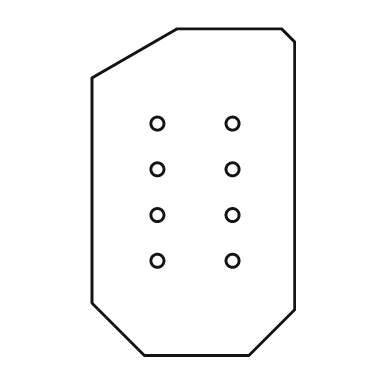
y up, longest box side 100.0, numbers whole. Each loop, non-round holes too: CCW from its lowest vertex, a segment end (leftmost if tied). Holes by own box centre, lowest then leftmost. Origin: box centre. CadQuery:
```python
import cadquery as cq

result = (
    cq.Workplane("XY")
    .moveTo(-15.0, -50.0)
    .lineTo(17.0, -50.0)
    .lineTo(31.0, -36.0)
    .lineTo(31.0, 46.0)
    .lineTo(27.0, 50.0)
    .lineTo(-5.0, 50.0)
    .lineTo(-31.0, 35.0)
    .lineTo(-31.0, -34.0)
    .close()
    .moveTo(-11.0, -21.0)
    .circle(2.0)
    .moveTo(12.0, -21.0)
    .circle(2.0)
    .moveTo(-11.0, -7.0)
    .circle(2.0)
    .moveTo(12.0, -7.0)
    .circle(2.0)
    .moveTo(-11.0, 7.0)
    .circle(2.0)
    .moveTo(12.0, 7.0)
    .circle(2.0)
    .moveTo(-11.0, 21.0)
    .circle(2.0)
    .moveTo(12.0, 21.0)
    .circle(2.0)
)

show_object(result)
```